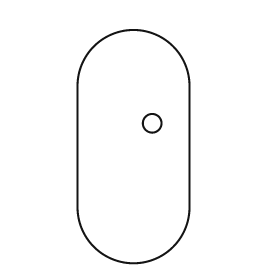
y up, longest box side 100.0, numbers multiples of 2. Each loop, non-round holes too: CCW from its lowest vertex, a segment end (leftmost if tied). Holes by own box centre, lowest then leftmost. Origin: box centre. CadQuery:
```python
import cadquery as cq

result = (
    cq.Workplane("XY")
    .moveTo(-24.0, -26.0)
    .threePointArc((0.0, -50.0), (24.0, -26.0))
    .lineTo(24.0, 26.0)
    .threePointArc((0.0, 50.0), (-24.0, 26.0))
    .close()
    .moveTo(8.0, 10.0)
    .circle(4.0)
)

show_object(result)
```